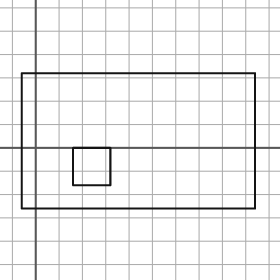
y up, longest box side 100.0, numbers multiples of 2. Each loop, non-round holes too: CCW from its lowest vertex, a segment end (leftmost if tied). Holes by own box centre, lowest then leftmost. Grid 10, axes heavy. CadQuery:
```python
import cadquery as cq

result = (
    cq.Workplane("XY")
    .moveTo(-6.0, -26.0)
    .lineTo(94.0, -26.0)
    .lineTo(94.0, 32.0)
    .lineTo(-6.0, 32.0)
    .close()
    .moveTo(16.0, -16.0)
    .lineTo(32.0, -16.0)
    .lineTo(32.0, 0.0)
    .lineTo(16.0, 0.0)
    .close()
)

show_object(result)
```